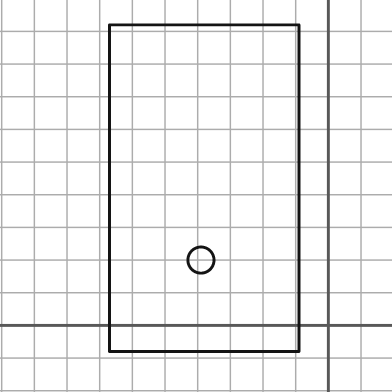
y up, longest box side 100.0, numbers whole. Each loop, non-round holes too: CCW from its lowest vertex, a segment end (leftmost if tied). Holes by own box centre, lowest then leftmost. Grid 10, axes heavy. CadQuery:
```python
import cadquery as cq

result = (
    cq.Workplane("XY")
    .moveTo(-67.0, -8.0)
    .lineTo(-9.0, -8.0)
    .lineTo(-9.0, 92.0)
    .lineTo(-67.0, 92.0)
    .close()
    .moveTo(-39.0, 20.0)
    .circle(4.0)
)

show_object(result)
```